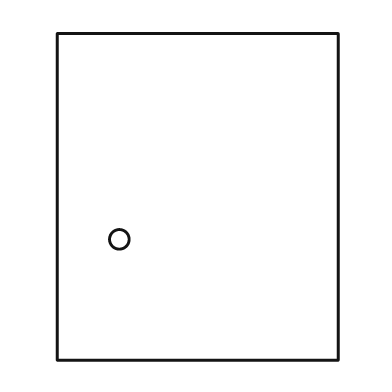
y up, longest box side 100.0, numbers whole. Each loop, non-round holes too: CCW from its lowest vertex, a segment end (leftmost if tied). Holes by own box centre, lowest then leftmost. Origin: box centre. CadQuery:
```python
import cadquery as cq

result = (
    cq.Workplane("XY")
    .moveTo(-43.0, -50.0)
    .lineTo(43.0, -50.0)
    .lineTo(43.0, 50.0)
    .lineTo(-43.0, 50.0)
    .close()
    .moveTo(-24.0, -13.0)
    .circle(3.0)
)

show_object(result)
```